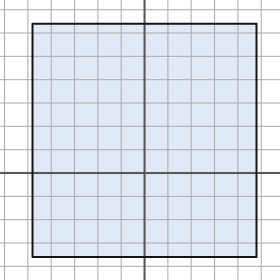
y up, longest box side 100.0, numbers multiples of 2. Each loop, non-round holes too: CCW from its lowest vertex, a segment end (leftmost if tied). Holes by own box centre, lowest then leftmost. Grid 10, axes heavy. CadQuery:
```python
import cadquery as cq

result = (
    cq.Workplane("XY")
    .moveTo(-48.0, -36.0)
    .lineTo(48.0, -36.0)
    .lineTo(48.0, 64.0)
    .lineTo(-48.0, 64.0)
    .close()
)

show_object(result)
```